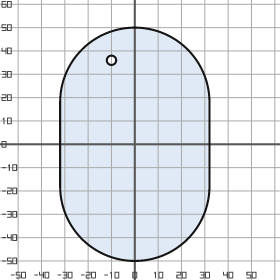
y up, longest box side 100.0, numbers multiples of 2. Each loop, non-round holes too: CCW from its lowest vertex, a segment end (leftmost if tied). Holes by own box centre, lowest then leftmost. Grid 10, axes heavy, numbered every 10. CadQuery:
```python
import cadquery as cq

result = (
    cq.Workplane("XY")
    .moveTo(-32.0, -18.0)
    .threePointArc((0.0, -50.0), (32.0, -18.0))
    .lineTo(32.0, 18.0)
    .threePointArc((0.0, 50.0), (-32.0, 18.0))
    .close()
    .moveTo(-10.0, 36.0)
    .circle(2.0)
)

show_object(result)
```